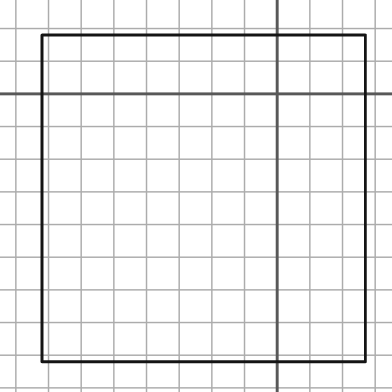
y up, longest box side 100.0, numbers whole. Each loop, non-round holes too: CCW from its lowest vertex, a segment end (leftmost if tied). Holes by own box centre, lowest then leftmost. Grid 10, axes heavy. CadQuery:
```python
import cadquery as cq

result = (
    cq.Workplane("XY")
    .moveTo(-72.0, -82.0)
    .lineTo(27.0, -82.0)
    .lineTo(27.0, 18.0)
    .lineTo(-72.0, 18.0)
    .close()
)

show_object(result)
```